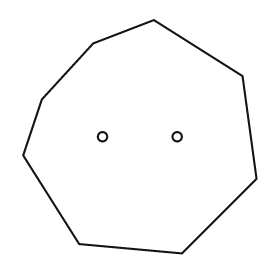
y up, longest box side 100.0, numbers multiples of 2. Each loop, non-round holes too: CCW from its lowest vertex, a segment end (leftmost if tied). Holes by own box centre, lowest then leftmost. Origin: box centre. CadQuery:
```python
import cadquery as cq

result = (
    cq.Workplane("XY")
    .moveTo(18.0, -50.0)
    .lineTo(50.0, -18.0)
    .lineTo(44.0, 26.0)
    .lineTo(6.0, 50.0)
    .lineTo(-20.0, 40.0)
    .lineTo(-42.0, 16.0)
    .lineTo(-50.0, -8.0)
    .lineTo(-26.0, -46.0)
    .close()
    .moveTo(-16.0, 0.0)
    .circle(2.0)
    .moveTo(16.0, 0.0)
    .circle(2.0)
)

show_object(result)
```